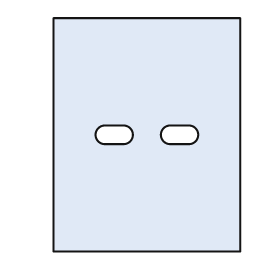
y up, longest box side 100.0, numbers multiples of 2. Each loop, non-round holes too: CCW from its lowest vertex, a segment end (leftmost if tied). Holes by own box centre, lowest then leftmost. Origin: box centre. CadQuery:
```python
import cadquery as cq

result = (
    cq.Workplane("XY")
    .moveTo(-40.0, -50.0)
    .lineTo(40.0, -50.0)
    .lineTo(40.0, 50.0)
    .lineTo(-40.0, 50.0)
    .close()
    .moveTo(-18.0, -4.0)
    .lineTo(-10.0, -4.0)
    .threePointArc((-6.0, 0.0), (-10.0, 4.0))
    .lineTo(-18.0, 4.0)
    .threePointArc((-22.0, 0.0), (-18.0, -4.0))
    .close()
    .moveTo(10.0, -4.0)
    .lineTo(18.0, -4.0)
    .threePointArc((22.0, 0.0), (18.0, 4.0))
    .lineTo(10.0, 4.0)
    .threePointArc((6.0, 0.0), (10.0, -4.0))
    .close()
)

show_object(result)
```